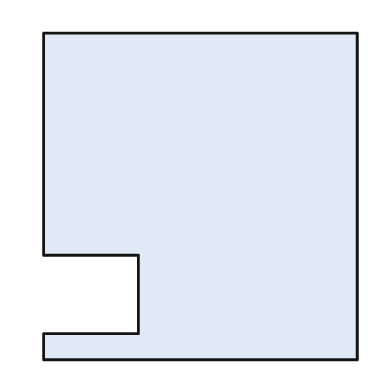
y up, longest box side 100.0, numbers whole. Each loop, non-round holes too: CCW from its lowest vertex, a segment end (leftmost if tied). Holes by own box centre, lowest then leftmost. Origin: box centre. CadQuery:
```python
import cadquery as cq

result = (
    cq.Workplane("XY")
    .moveTo(-48.0, -50.0)
    .lineTo(48.0, -50.0)
    .lineTo(48.0, 50.0)
    .lineTo(-48.0, 50.0)
    .lineTo(-48.0, -18.0)
    .lineTo(-19.0, -18.0)
    .lineTo(-19.0, -42.0)
    .lineTo(-48.0, -42.0)
    .close()
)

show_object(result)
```